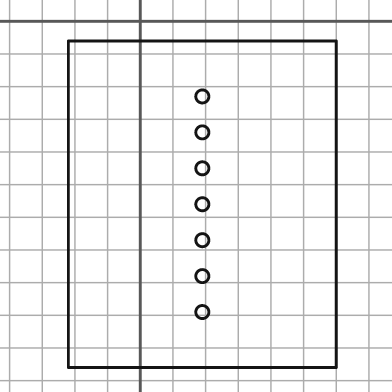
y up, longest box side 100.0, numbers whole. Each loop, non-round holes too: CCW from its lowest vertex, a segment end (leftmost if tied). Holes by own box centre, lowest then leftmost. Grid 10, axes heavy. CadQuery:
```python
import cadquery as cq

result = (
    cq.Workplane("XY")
    .moveTo(-22.0, -106.0)
    .lineTo(60.0, -106.0)
    .lineTo(60.0, -6.0)
    .lineTo(-22.0, -6.0)
    .close()
    .moveTo(19.0, -89.0)
    .circle(2.0)
    .moveTo(19.0, -78.0)
    .circle(2.0)
    .moveTo(19.0, -67.0)
    .circle(2.0)
    .moveTo(19.0, -56.0)
    .circle(2.0)
    .moveTo(19.0, -45.0)
    .circle(2.0)
    .moveTo(19.0, -34.0)
    .circle(2.0)
    .moveTo(19.0, -23.0)
    .circle(2.0)
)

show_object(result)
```